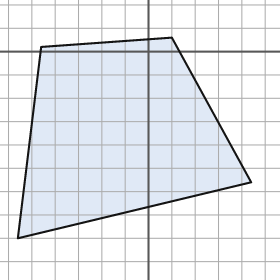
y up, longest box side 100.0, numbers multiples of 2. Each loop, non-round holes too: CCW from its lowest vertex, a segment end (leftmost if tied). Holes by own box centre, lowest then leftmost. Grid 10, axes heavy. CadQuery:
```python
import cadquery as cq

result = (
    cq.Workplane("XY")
    .moveTo(-56.0, -80.0)
    .lineTo(44.0, -56.0)
    .lineTo(10.0, 6.0)
    .lineTo(-46.0, 2.0)
    .close()
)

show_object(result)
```